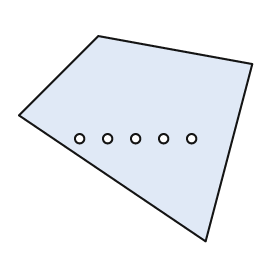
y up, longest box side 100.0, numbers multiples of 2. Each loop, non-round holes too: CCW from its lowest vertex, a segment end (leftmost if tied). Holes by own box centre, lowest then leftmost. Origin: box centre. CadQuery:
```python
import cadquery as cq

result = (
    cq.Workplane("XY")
    .moveTo(30.0, -44.0)
    .lineTo(50.0, 32.0)
    .lineTo(-16.0, 44.0)
    .lineTo(-50.0, 10.0)
    .close()
    .moveTo(-24.0, 0.0)
    .circle(2.0)
    .moveTo(-12.0, 0.0)
    .circle(2.0)
    .moveTo(0.0, 0.0)
    .circle(2.0)
    .moveTo(12.0, 0.0)
    .circle(2.0)
    .moveTo(24.0, 0.0)
    .circle(2.0)
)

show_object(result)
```